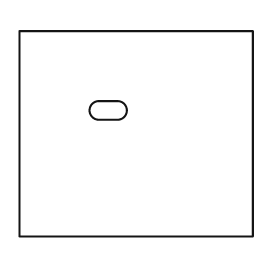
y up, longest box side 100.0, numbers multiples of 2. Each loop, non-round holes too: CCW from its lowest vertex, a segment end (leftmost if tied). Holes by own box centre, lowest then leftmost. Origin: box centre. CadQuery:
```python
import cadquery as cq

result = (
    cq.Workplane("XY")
    .moveTo(-50.0, -44.0)
    .lineTo(50.0, -44.0)
    .lineTo(50.0, 44.0)
    .lineTo(-50.0, 44.0)
    .close()
    .moveTo(-16.0, 6.0)
    .lineTo(-8.0, 6.0)
    .threePointArc((-4.0, 10.0), (-8.0, 14.0))
    .lineTo(-16.0, 14.0)
    .threePointArc((-20.0, 10.0), (-16.0, 6.0))
    .close()
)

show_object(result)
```